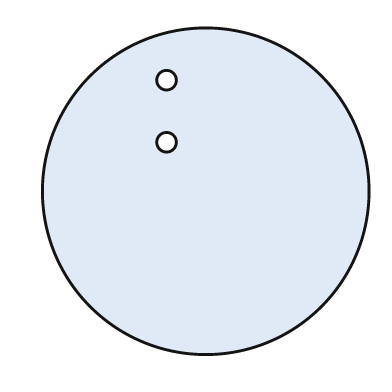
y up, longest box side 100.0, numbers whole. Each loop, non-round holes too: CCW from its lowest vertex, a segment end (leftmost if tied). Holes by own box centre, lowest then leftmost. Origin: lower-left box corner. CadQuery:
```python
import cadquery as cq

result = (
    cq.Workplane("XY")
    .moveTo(50.0, 50.0)
    .circle(50.0)
    .moveTo(38.0, 65.0)
    .circle(3.0)
    .moveTo(38.0, 84.0)
    .circle(3.0)
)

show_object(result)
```